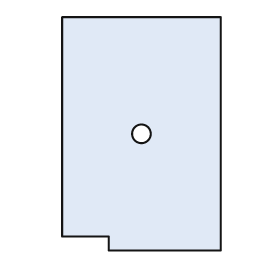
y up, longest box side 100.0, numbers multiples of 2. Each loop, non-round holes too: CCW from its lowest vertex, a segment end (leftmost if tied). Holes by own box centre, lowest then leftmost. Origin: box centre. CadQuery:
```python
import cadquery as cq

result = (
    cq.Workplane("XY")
    .moveTo(-14.0, -50.0)
    .lineTo(34.0, -50.0)
    .lineTo(34.0, 50.0)
    .lineTo(-34.0, 50.0)
    .lineTo(-34.0, -44.0)
    .lineTo(-14.0, -44.0)
    .close()
    .moveTo(0.0, 0.0)
    .circle(4.0)
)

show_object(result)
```